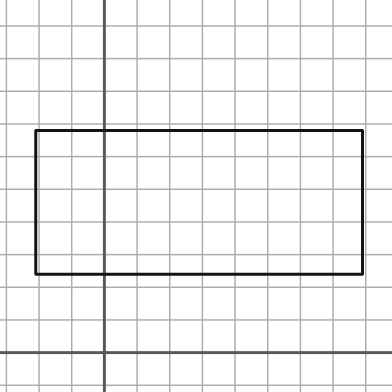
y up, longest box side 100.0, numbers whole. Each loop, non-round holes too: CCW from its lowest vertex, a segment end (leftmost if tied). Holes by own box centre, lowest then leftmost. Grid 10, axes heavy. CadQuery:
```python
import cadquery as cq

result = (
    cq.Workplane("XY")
    .moveTo(-21.0, 24.0)
    .lineTo(79.0, 24.0)
    .lineTo(79.0, 68.0)
    .lineTo(-21.0, 68.0)
    .close()
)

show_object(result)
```